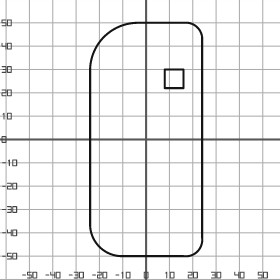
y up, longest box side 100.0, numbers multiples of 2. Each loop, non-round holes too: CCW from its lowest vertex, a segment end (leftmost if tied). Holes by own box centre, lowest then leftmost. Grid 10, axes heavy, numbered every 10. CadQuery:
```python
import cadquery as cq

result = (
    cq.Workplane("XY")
    .moveTo(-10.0, -50.0)
    .lineTo(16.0, -50.0)
    .threePointArc((22.0, -48.0), (24.0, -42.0))
    .lineTo(24.0, 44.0)
    .threePointArc((22.0, 48.0), (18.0, 50.0))
    .lineTo(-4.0, 50.0)
    .threePointArc((-18.0, 44.0), (-24.0, 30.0))
    .lineTo(-24.0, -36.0)
    .threePointArc((-20.0, -46.0), (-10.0, -50.0))
    .close()
    .moveTo(8.0, 22.0)
    .lineTo(16.0, 22.0)
    .lineTo(16.0, 30.0)
    .lineTo(8.0, 30.0)
    .close()
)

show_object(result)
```